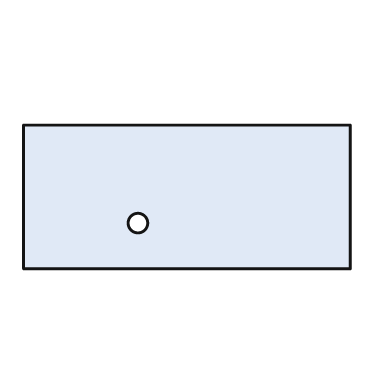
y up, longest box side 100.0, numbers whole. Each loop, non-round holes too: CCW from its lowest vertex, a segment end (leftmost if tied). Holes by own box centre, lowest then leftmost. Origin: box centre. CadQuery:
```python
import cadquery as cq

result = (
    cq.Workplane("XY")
    .moveTo(-50.0, -22.0)
    .lineTo(50.0, -22.0)
    .lineTo(50.0, 22.0)
    .lineTo(-50.0, 22.0)
    .close()
    .moveTo(-15.0, -8.0)
    .circle(3.0)
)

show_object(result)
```